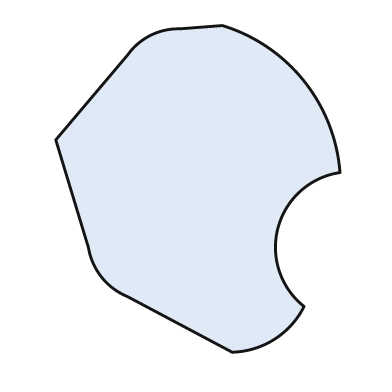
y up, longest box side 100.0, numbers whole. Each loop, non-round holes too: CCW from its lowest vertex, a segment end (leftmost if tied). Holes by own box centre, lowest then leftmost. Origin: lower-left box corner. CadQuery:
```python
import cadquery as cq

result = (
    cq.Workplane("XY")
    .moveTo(54.0, 0.0)
    .threePointArc((67.0, 4.0), (76.0, 14.0))
    .threePointArc((68.0, 38.0), (87.0, 55.0))
    .threePointArc((76.0, 83.0), (51.0, 100.0))
    .lineTo(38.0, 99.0)
    .threePointArc((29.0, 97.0), (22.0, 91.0))
    .lineTo(0.0, 65.0)
    .lineTo(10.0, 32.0)
    .threePointArc((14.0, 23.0), (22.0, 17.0))
    .close()
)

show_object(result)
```